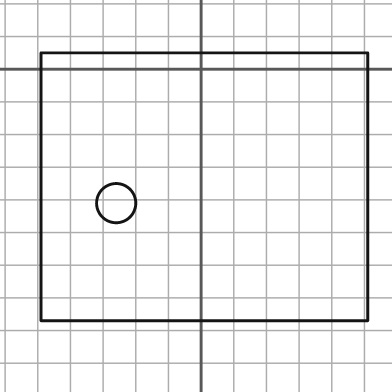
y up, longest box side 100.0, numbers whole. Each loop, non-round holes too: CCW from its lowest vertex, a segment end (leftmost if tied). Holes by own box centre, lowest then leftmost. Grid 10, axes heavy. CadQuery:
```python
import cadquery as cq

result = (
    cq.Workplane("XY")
    .moveTo(-49.0, -77.0)
    .lineTo(51.0, -77.0)
    .lineTo(51.0, 5.0)
    .lineTo(-49.0, 5.0)
    .close()
    .moveTo(-26.0, -41.0)
    .circle(6.0)
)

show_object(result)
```